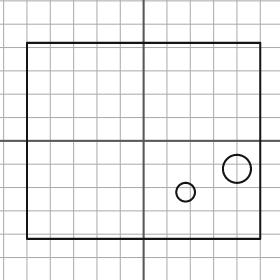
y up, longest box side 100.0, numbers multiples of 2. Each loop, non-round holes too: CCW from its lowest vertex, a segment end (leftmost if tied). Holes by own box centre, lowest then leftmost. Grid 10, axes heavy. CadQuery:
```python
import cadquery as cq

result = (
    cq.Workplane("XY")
    .moveTo(-50.0, -42.0)
    .lineTo(50.0, -42.0)
    .lineTo(50.0, 42.0)
    .lineTo(-50.0, 42.0)
    .close()
    .moveTo(18.0, -22.0)
    .circle(4.0)
    .moveTo(40.0, -12.0)
    .circle(6.0)
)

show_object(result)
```